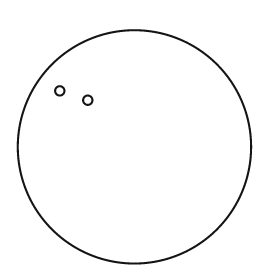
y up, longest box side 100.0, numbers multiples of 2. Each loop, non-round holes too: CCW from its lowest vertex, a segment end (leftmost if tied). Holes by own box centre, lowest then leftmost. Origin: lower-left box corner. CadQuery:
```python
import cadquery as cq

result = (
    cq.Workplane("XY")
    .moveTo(50.0, 50.0)
    .circle(50.0)
    .moveTo(30.0, 70.0)
    .circle(2.0)
    .moveTo(18.0, 74.0)
    .circle(2.0)
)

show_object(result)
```